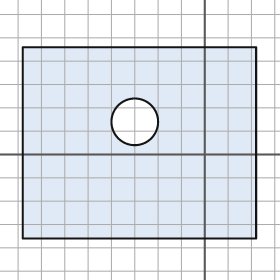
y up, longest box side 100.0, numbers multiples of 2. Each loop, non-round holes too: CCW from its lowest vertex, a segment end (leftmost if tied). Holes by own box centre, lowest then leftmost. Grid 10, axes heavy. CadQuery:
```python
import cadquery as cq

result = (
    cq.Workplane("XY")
    .moveTo(-78.0, -36.0)
    .lineTo(22.0, -36.0)
    .lineTo(22.0, 46.0)
    .lineTo(-78.0, 46.0)
    .close()
    .moveTo(-30.0, 14.0)
    .circle(10.0)
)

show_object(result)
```